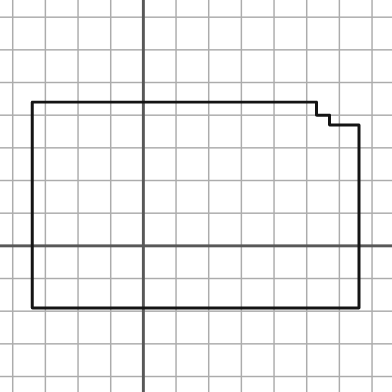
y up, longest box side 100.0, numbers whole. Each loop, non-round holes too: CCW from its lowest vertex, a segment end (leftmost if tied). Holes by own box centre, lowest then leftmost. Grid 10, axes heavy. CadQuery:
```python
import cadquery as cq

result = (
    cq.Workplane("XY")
    .moveTo(-34.0, -19.0)
    .lineTo(66.0, -19.0)
    .lineTo(66.0, 37.0)
    .lineTo(57.0, 37.0)
    .lineTo(57.0, 40.0)
    .lineTo(53.0, 40.0)
    .lineTo(53.0, 44.0)
    .lineTo(-34.0, 44.0)
    .close()
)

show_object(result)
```